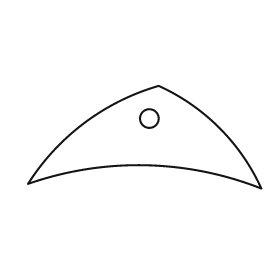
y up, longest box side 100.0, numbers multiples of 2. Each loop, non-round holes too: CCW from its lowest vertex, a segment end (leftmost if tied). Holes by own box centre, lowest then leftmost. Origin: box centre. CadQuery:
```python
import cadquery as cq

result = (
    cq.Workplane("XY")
    .moveTo(50.0, -22.0)
    .threePointArc((32.0, 4.0), (6.0, 22.0))
    .threePointArc((-26.0, 6.0), (-50.0, -20.0))
    .threePointArc((0.0, -12.0), (50.0, -22.0))
    .close()
    .moveTo(2.0, 8.0)
    .circle(4.0)
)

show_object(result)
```